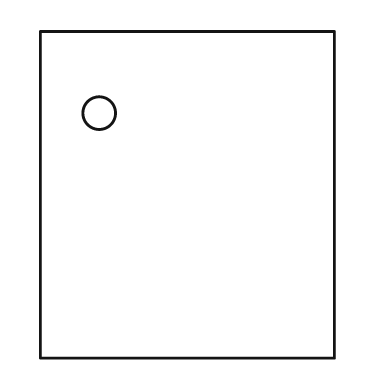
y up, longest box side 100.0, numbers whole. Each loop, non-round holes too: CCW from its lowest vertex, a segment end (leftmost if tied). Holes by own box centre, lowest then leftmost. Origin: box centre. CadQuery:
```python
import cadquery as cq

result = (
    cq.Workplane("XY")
    .moveTo(-45.0, -50.0)
    .lineTo(45.0, -50.0)
    .lineTo(45.0, 50.0)
    .lineTo(-45.0, 50.0)
    .close()
    .moveTo(-27.0, 25.0)
    .circle(5.0)
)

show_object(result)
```